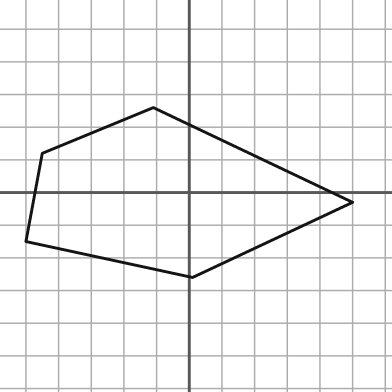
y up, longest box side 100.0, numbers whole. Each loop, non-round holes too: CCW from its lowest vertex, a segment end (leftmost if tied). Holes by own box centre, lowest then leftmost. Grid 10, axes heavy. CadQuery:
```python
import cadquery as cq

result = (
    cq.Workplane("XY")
    .moveTo(1.0, -26.0)
    .lineTo(50.0, -3.0)
    .lineTo(-11.0, 26.0)
    .lineTo(-45.0, 12.0)
    .lineTo(-50.0, -15.0)
    .close()
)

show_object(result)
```